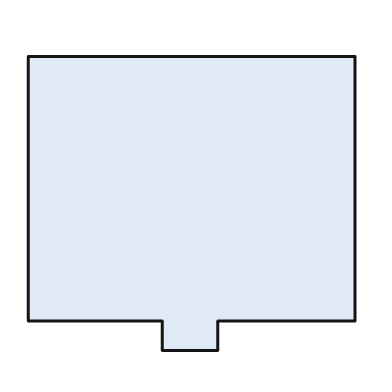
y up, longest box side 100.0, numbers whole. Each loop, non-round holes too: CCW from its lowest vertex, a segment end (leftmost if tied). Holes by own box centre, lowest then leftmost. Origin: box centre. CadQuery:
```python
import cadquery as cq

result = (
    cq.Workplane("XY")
    .moveTo(-9.0, -45.0)
    .lineTo(8.0, -45.0)
    .lineTo(8.0, -36.0)
    .lineTo(50.0, -36.0)
    .lineTo(50.0, 45.0)
    .lineTo(-50.0, 45.0)
    .lineTo(-50.0, -36.0)
    .lineTo(-9.0, -36.0)
    .close()
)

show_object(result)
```